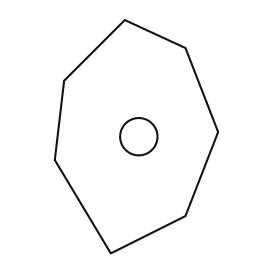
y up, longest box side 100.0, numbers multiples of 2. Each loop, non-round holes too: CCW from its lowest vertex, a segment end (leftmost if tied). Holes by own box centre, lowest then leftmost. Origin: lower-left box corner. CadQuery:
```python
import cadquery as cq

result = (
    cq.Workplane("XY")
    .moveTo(24.0, 0.0)
    .lineTo(56.0, 16.0)
    .lineTo(70.0, 52.0)
    .lineTo(56.0, 88.0)
    .lineTo(30.0, 100.0)
    .lineTo(4.0, 74.0)
    .lineTo(0.0, 40.0)
    .close()
    .moveTo(36.0, 50.0)
    .circle(8.0)
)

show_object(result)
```